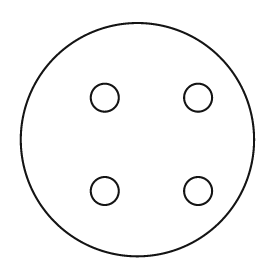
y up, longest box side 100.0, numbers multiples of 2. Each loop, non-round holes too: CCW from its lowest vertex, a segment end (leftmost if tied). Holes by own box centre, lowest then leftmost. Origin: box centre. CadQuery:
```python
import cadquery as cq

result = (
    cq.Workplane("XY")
    .moveTo(0.0, 0.0)
    .circle(50.0)
    .moveTo(-14.0, -22.0)
    .circle(6.0)
    .moveTo(26.0, -22.0)
    .circle(6.0)
    .moveTo(-14.0, 18.0)
    .circle(6.0)
    .moveTo(26.0, 18.0)
    .circle(6.0)
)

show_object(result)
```